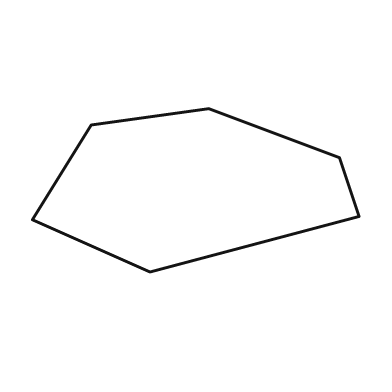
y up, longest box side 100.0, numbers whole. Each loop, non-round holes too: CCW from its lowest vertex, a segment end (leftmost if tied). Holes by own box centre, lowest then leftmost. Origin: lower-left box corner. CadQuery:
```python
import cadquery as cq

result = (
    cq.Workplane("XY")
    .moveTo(36.0, 0.0)
    .lineTo(100.0, 17.0)
    .lineTo(94.0, 35.0)
    .lineTo(54.0, 50.0)
    .lineTo(18.0, 45.0)
    .lineTo(0.0, 16.0)
    .close()
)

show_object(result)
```